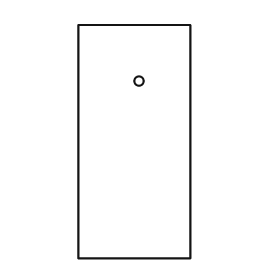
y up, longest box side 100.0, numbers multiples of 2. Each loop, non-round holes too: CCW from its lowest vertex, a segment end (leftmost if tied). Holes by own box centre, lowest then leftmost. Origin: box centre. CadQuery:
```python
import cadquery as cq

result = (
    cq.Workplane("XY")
    .moveTo(-24.0, -50.0)
    .lineTo(24.0, -50.0)
    .lineTo(24.0, 50.0)
    .lineTo(-24.0, 50.0)
    .close()
    .moveTo(2.0, 26.0)
    .circle(2.0)
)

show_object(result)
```